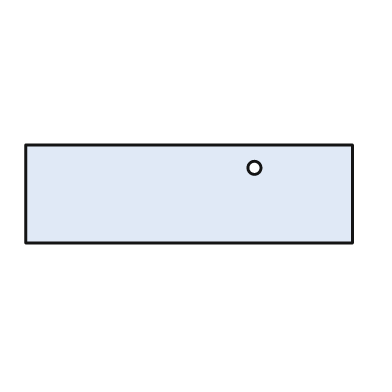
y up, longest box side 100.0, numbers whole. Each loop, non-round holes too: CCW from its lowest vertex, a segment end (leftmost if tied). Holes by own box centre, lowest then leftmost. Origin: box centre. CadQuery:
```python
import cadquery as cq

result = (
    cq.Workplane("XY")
    .moveTo(-50.0, -15.0)
    .lineTo(50.0, -15.0)
    .lineTo(50.0, 15.0)
    .lineTo(-50.0, 15.0)
    .close()
    .moveTo(20.0, 8.0)
    .circle(2.0)
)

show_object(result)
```